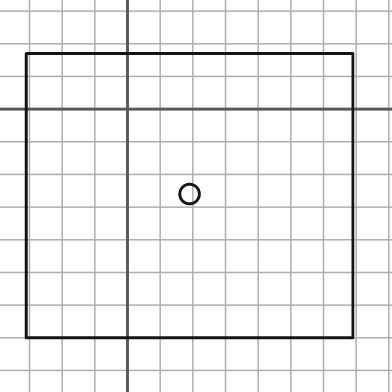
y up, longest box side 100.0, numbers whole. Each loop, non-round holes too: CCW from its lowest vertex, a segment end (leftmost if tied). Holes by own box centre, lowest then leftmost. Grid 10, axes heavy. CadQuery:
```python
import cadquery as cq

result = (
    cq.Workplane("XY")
    .moveTo(-31.0, -70.0)
    .lineTo(69.0, -70.0)
    .lineTo(69.0, 17.0)
    .lineTo(-31.0, 17.0)
    .close()
    .moveTo(19.0, -26.0)
    .circle(3.0)
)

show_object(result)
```